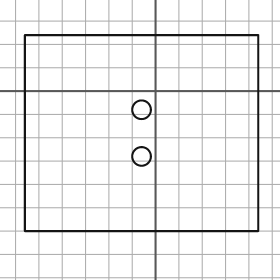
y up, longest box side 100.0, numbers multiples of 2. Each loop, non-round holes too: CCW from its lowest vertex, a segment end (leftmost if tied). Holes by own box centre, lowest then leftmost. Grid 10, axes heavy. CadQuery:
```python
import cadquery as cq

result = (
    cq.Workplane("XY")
    .moveTo(-56.0, -60.0)
    .lineTo(44.0, -60.0)
    .lineTo(44.0, 24.0)
    .lineTo(-56.0, 24.0)
    .close()
    .moveTo(-6.0, -28.0)
    .circle(4.0)
    .moveTo(-6.0, -8.0)
    .circle(4.0)
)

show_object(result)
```